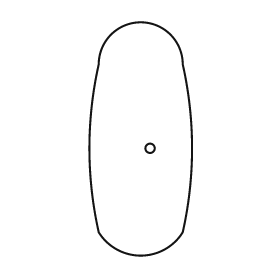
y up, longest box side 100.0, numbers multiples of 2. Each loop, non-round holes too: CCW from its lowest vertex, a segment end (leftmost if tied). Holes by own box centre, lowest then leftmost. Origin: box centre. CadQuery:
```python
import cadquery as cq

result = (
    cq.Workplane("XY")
    .moveTo(-18.0, -40.0)
    .threePointArc((0.0, -50.0), (18.0, -40.0))
    .threePointArc((22.0, -4.0), (18.0, 32.0))
    .threePointArc((0.0, 50.0), (-18.0, 32.0))
    .threePointArc((-22.0, -4.0), (-18.0, -40.0))
    .close()
    .moveTo(4.0, -4.0)
    .circle(2.0)
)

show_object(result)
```